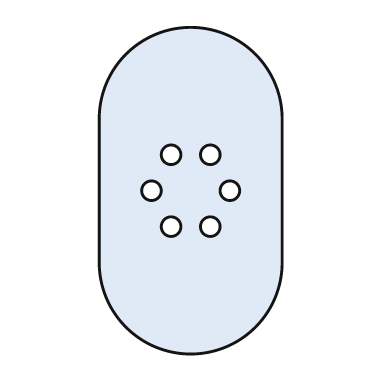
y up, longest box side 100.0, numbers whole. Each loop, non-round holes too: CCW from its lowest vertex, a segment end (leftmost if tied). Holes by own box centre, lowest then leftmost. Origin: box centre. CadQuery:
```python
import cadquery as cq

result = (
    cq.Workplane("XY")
    .moveTo(-28.0, -22.0)
    .threePointArc((0.0, -50.0), (28.0, -22.0))
    .lineTo(28.0, 22.0)
    .threePointArc((0.0, 50.0), (-28.0, 22.0))
    .close()
    .moveTo(-6.0, -11.0)
    .circle(3.0)
    .moveTo(6.0, -11.0)
    .circle(3.0)
    .moveTo(-12.0, 0.0)
    .circle(3.0)
    .moveTo(12.0, 0.0)
    .circle(3.0)
    .moveTo(-6.0, 11.0)
    .circle(3.0)
    .moveTo(6.0, 11.0)
    .circle(3.0)
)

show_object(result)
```